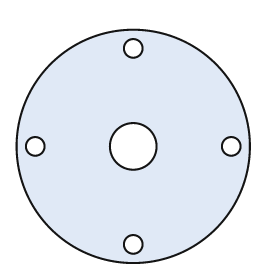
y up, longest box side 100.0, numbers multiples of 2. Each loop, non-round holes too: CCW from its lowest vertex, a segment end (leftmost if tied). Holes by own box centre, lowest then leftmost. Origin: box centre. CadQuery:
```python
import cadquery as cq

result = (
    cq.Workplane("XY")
    .moveTo(0.0, 0.0)
    .circle(50.0)
    .moveTo(0.0, -42.0)
    .circle(4.0)
    .moveTo(-42.0, 0.0)
    .circle(4.0)
    .moveTo(0.0, 0.0)
    .circle(10.0)
    .moveTo(42.0, 0.0)
    .circle(4.0)
    .moveTo(0.0, 42.0)
    .circle(4.0)
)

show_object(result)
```